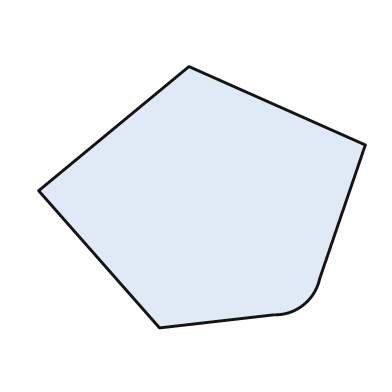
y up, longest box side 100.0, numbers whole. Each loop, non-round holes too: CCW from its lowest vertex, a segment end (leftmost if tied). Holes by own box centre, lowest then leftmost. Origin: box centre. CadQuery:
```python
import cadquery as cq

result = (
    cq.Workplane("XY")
    .moveTo(-13.0, -40.0)
    .lineTo(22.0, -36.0)
    .threePointArc((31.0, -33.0), (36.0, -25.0))
    .lineTo(50.0, 16.0)
    .lineTo(-4.0, 40.0)
    .lineTo(-50.0, 2.0)
    .close()
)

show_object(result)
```